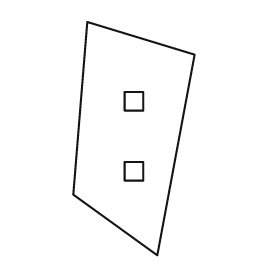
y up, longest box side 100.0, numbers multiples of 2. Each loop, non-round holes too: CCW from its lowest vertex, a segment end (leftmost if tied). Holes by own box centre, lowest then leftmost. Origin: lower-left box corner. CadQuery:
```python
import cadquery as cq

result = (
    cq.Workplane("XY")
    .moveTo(36.0, 0.0)
    .lineTo(52.0, 86.0)
    .lineTo(6.0, 100.0)
    .lineTo(0.0, 26.0)
    .close()
    .moveTo(22.0, 32.0)
    .lineTo(30.0, 32.0)
    .lineTo(30.0, 40.0)
    .lineTo(22.0, 40.0)
    .close()
    .moveTo(22.0, 62.0)
    .lineTo(30.0, 62.0)
    .lineTo(30.0, 70.0)
    .lineTo(22.0, 70.0)
    .close()
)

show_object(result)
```